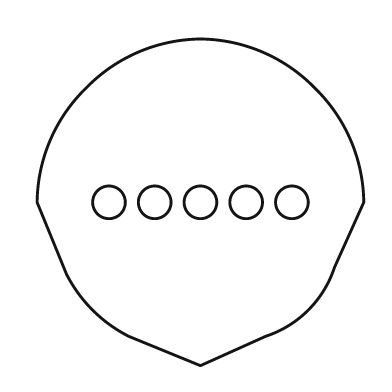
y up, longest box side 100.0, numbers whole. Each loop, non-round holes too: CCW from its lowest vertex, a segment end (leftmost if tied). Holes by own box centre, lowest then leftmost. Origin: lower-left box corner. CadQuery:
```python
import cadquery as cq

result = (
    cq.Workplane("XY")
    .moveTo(50.0, 0.0)
    .lineTo(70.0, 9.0)
    .threePointArc((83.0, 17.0), (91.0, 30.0))
    .lineTo(100.0, 50.0)
    .threePointArc((96.0, 69.0), (85.0, 85.0))
    .threePointArc((69.0, 96.0), (50.0, 100.0))
    .threePointArc((31.0, 96.0), (15.0, 85.0))
    .threePointArc((4.0, 69.0), (0.0, 50.0))
    .lineTo(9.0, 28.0)
    .threePointArc((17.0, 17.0), (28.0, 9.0))
    .close()
    .moveTo(22.0, 50.0)
    .circle(5.0)
    .moveTo(36.0, 50.0)
    .circle(5.0)
    .moveTo(50.0, 50.0)
    .circle(5.0)
    .moveTo(64.0, 50.0)
    .circle(5.0)
    .moveTo(78.0, 50.0)
    .circle(5.0)
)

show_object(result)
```